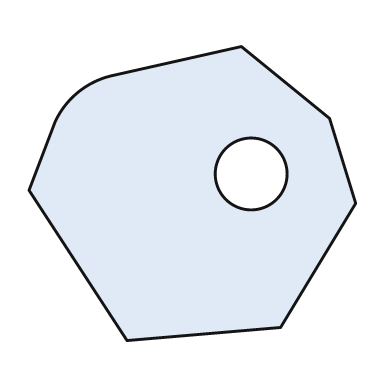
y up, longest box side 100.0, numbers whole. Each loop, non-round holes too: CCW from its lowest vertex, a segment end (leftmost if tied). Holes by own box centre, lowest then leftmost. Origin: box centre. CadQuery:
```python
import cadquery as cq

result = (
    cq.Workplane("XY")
    .moveTo(-20.0, -45.0)
    .lineTo(27.0, -41.0)
    .lineTo(50.0, -3.0)
    .lineTo(42.0, 23.0)
    .lineTo(15.0, 45.0)
    .lineTo(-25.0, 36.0)
    .threePointArc((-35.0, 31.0), (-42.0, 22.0))
    .lineTo(-50.0, 1.0)
    .close()
    .moveTo(18.0, 6.0)
    .circle(11.0)
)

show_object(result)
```